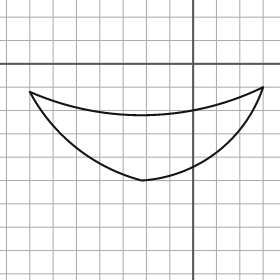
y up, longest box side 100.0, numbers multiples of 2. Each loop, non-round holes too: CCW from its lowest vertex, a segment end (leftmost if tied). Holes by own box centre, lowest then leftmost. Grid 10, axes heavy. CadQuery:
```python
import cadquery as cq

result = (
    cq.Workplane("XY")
    .moveTo(-22.0, -50.0)
    .threePointArc((10.0, -38.0), (30.0, -10.0))
    .threePointArc((-20.0, -22.0), (-70.0, -12.0))
    .threePointArc((-50.0, -36.0), (-22.0, -50.0))
    .close()
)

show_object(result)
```